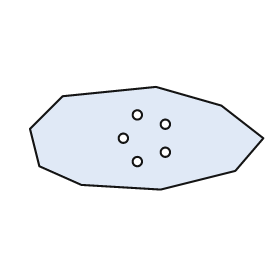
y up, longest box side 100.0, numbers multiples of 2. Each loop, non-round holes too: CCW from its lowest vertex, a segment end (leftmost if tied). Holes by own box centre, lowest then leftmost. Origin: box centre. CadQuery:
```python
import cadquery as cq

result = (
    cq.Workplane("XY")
    .moveTo(6.0, -22.0)
    .lineTo(38.0, -14.0)
    .lineTo(50.0, 0.0)
    .lineTo(32.0, 14.0)
    .lineTo(4.0, 22.0)
    .lineTo(-36.0, 18.0)
    .lineTo(-50.0, 4.0)
    .lineTo(-46.0, -12.0)
    .lineTo(-28.0, -20.0)
    .close()
    .moveTo(-4.0, -10.0)
    .circle(2.0)
    .moveTo(8.0, -6.0)
    .circle(2.0)
    .moveTo(-10.0, 0.0)
    .circle(2.0)
    .moveTo(8.0, 6.0)
    .circle(2.0)
    .moveTo(-4.0, 10.0)
    .circle(2.0)
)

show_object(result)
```